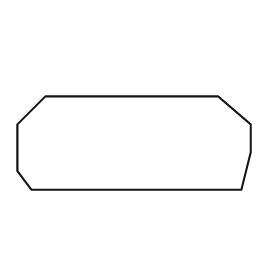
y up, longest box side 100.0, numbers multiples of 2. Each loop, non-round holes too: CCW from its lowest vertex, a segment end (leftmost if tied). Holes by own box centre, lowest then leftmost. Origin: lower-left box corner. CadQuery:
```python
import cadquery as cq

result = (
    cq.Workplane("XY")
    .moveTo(6.0, 0.0)
    .lineTo(96.0, 0.0)
    .lineTo(100.0, 16.0)
    .lineTo(100.0, 28.0)
    .lineTo(86.0, 40.0)
    .lineTo(12.0, 40.0)
    .lineTo(0.0, 28.0)
    .lineTo(0.0, 8.0)
    .close()
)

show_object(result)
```